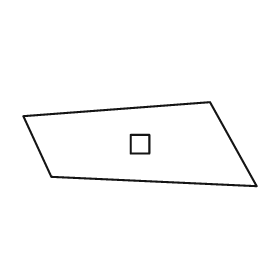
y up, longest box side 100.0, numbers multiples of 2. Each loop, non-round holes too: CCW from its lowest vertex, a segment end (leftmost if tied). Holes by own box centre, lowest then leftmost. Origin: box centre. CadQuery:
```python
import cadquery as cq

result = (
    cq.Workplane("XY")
    .moveTo(50.0, -18.0)
    .lineTo(30.0, 18.0)
    .lineTo(-50.0, 12.0)
    .lineTo(-38.0, -14.0)
    .close()
    .moveTo(-4.0, -4.0)
    .lineTo(4.0, -4.0)
    .lineTo(4.0, 4.0)
    .lineTo(-4.0, 4.0)
    .close()
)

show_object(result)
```